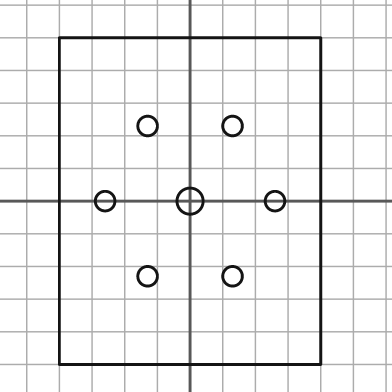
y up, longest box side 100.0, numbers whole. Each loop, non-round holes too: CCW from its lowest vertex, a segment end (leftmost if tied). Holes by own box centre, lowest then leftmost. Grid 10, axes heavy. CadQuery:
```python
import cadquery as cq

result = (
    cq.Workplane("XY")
    .moveTo(-40.0, -50.0)
    .lineTo(40.0, -50.0)
    .lineTo(40.0, 50.0)
    .lineTo(-40.0, 50.0)
    .close()
    .moveTo(-13.0, -23.0)
    .circle(3.0)
    .moveTo(13.0, -23.0)
    .circle(3.0)
    .moveTo(-26.0, 0.0)
    .circle(3.0)
    .moveTo(0.0, 0.0)
    .circle(4.0)
    .moveTo(26.0, 0.0)
    .circle(3.0)
    .moveTo(-13.0, 23.0)
    .circle(3.0)
    .moveTo(13.0, 23.0)
    .circle(3.0)
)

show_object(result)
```